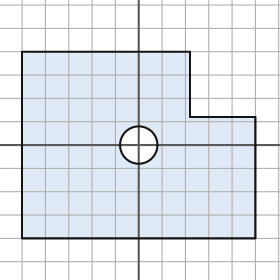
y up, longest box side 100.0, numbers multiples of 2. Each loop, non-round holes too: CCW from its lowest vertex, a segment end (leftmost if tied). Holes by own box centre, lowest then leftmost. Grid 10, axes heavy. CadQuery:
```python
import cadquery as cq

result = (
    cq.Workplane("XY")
    .moveTo(-50.0, -40.0)
    .lineTo(50.0, -40.0)
    .lineTo(50.0, 12.0)
    .lineTo(22.0, 12.0)
    .lineTo(22.0, 40.0)
    .lineTo(-50.0, 40.0)
    .close()
    .moveTo(0.0, 0.0)
    .circle(8.0)
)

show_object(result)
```